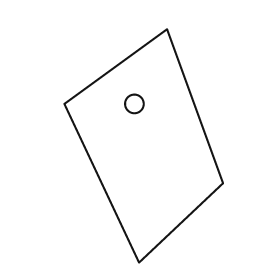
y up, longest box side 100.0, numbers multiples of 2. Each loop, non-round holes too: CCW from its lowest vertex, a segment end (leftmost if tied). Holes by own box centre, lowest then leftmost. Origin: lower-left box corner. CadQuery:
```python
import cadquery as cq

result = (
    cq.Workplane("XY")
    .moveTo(32.0, 0.0)
    .lineTo(68.0, 34.0)
    .lineTo(44.0, 100.0)
    .lineTo(0.0, 68.0)
    .close()
    .moveTo(30.0, 68.0)
    .circle(4.0)
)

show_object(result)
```